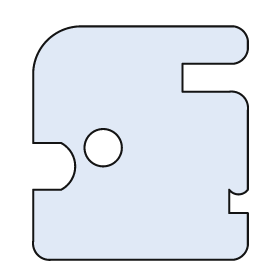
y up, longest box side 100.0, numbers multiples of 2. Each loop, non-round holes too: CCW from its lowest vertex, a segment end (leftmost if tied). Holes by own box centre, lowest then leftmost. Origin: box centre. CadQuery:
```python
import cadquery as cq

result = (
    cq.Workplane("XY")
    .moveTo(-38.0, -50.0)
    .lineTo(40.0, -50.0)
    .threePointArc((44.0, -48.0), (46.0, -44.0))
    .lineTo(46.0, -30.0)
    .lineTo(38.0, -30.0)
    .lineTo(38.0, -20.0)
    .threePointArc((42.0, -22.0), (46.0, -20.0))
    .lineTo(46.0, 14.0)
    .threePointArc((44.0, 20.0), (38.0, 22.0))
    .lineTo(18.0, 22.0)
    .lineTo(18.0, 34.0)
    .lineTo(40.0, 34.0)
    .threePointArc((44.0, 36.0), (46.0, 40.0))
    .lineTo(46.0, 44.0)
    .threePointArc((44.0, 48.0), (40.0, 50.0))
    .lineTo(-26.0, 50.0)
    .threePointArc((-40.0, 44.0), (-46.0, 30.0))
    .lineTo(-46.0, 0.0)
    .lineTo(-34.0, 0.0)
    .threePointArc((-28.0, -10.0), (-34.0, -20.0))
    .lineTo(-46.0, -20.0)
    .lineTo(-46.0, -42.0)
    .threePointArc((-44.0, -48.0), (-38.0, -50.0))
    .close()
    .moveTo(-16.0, -2.0)
    .circle(8.0)
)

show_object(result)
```